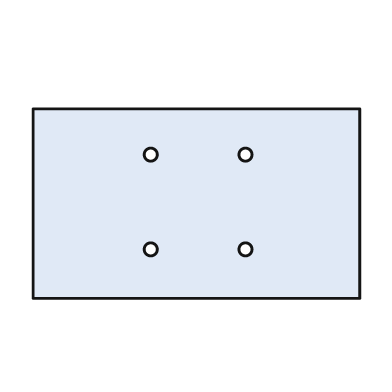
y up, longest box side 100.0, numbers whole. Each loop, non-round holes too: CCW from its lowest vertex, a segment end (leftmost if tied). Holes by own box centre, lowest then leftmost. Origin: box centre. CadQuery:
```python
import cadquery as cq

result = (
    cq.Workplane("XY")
    .moveTo(-50.0, -29.0)
    .lineTo(50.0, -29.0)
    .lineTo(50.0, 29.0)
    .lineTo(-50.0, 29.0)
    .close()
    .moveTo(-14.0, -14.0)
    .circle(2.0)
    .moveTo(15.0, -14.0)
    .circle(2.0)
    .moveTo(-14.0, 15.0)
    .circle(2.0)
    .moveTo(15.0, 15.0)
    .circle(2.0)
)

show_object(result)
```